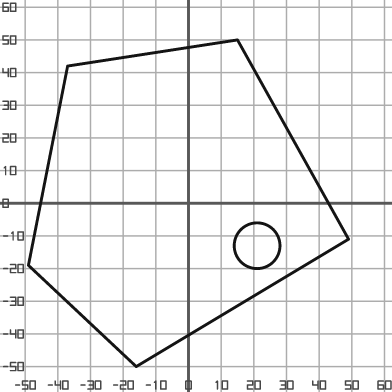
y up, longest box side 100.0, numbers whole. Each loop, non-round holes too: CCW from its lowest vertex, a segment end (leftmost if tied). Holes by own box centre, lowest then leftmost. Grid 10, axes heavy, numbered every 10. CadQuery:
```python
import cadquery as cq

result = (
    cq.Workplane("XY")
    .moveTo(-16.0, -50.0)
    .lineTo(49.0, -11.0)
    .lineTo(15.0, 50.0)
    .lineTo(-37.0, 42.0)
    .lineTo(-49.0, -19.0)
    .close()
    .moveTo(21.0, -13.0)
    .circle(7.0)
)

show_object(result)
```